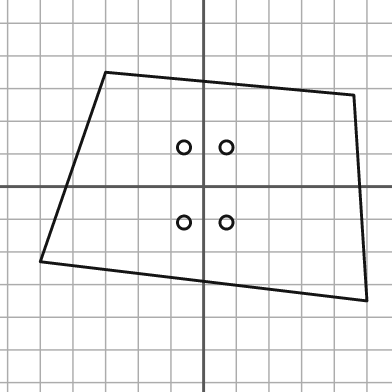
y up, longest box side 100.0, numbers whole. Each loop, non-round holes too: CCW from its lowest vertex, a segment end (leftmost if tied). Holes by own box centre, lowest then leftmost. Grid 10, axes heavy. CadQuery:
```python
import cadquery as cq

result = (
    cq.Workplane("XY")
    .moveTo(50.0, -35.0)
    .lineTo(46.0, 28.0)
    .lineTo(-30.0, 35.0)
    .lineTo(-50.0, -23.0)
    .close()
    .moveTo(-6.0, -11.0)
    .circle(2.0)
    .moveTo(7.0, -11.0)
    .circle(2.0)
    .moveTo(-6.0, 12.0)
    .circle(2.0)
    .moveTo(7.0, 12.0)
    .circle(2.0)
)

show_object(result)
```